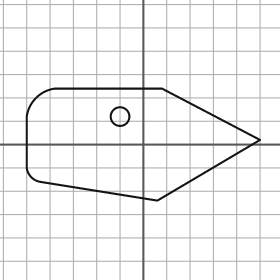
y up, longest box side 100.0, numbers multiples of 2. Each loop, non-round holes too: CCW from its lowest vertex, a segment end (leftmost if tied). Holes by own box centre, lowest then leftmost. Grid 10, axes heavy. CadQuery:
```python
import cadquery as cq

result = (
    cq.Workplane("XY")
    .moveTo(6.0, -24.0)
    .lineTo(50.0, 2.0)
    .lineTo(8.0, 24.0)
    .lineTo(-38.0, 24.0)
    .threePointArc((-46.0, 20.0), (-50.0, 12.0))
    .lineTo(-50.0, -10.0)
    .threePointArc((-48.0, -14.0), (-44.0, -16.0))
    .close()
    .moveTo(-10.0, 12.0)
    .circle(4.0)
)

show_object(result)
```